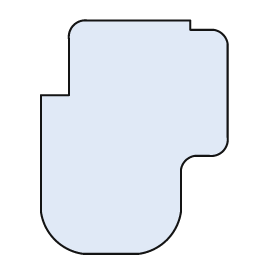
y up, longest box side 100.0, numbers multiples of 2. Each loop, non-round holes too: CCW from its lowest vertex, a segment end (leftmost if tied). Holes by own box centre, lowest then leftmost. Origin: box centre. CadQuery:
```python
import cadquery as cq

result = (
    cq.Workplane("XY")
    .moveTo(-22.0, -50.0)
    .lineTo(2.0, -50.0)
    .threePointArc((14.0, -44.0), (20.0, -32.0))
    .lineTo(20.0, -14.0)
    .threePointArc((22.0, -10.0), (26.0, -8.0))
    .lineTo(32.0, -8.0)
    .threePointArc((38.0, -6.0), (40.0, 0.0))
    .lineTo(40.0, 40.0)
    .threePointArc((38.0, 44.0), (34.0, 46.0))
    .lineTo(24.0, 46.0)
    .lineTo(24.0, 50.0)
    .lineTo(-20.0, 50.0)
    .threePointArc((-26.0, 48.0), (-28.0, 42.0))
    .lineTo(-28.0, 18.0)
    .lineTo(-40.0, 18.0)
    .lineTo(-40.0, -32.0)
    .threePointArc((-34.0, -44.0), (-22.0, -50.0))
    .close()
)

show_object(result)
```